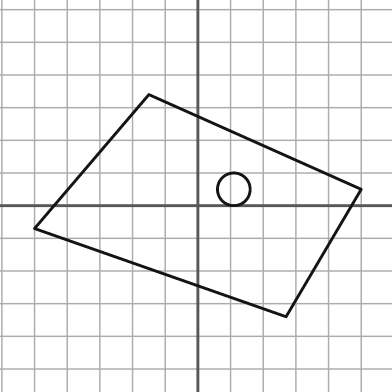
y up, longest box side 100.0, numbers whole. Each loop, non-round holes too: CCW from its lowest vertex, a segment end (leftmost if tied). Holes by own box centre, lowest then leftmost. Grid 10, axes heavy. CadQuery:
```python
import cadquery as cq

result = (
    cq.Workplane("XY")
    .moveTo(27.0, -34.0)
    .lineTo(50.0, 5.0)
    .lineTo(-15.0, 34.0)
    .lineTo(-50.0, -7.0)
    .close()
    .moveTo(11.0, 5.0)
    .circle(5.0)
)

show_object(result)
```